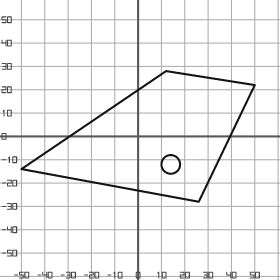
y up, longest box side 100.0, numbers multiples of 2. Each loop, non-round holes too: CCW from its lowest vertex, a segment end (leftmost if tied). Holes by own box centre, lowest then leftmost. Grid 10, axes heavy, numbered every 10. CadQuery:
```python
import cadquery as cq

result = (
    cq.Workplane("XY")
    .moveTo(26.0, -28.0)
    .lineTo(50.0, 22.0)
    .lineTo(12.0, 28.0)
    .lineTo(-50.0, -14.0)
    .close()
    .moveTo(14.0, -12.0)
    .circle(4.0)
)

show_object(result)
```